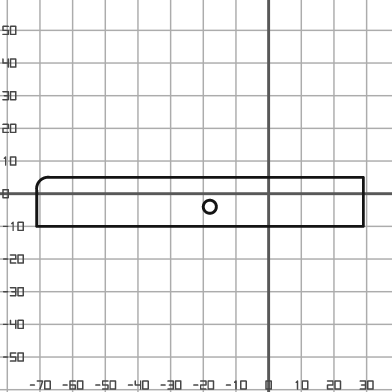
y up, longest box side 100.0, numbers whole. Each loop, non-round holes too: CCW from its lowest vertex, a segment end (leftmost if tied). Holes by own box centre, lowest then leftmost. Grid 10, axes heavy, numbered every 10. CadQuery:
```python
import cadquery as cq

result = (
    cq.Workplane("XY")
    .moveTo(-71.0, -10.0)
    .lineTo(29.0, -10.0)
    .lineTo(29.0, 5.0)
    .lineTo(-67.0, 5.0)
    .threePointArc((-70.0, 4.0), (-71.0, 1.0))
    .close()
    .moveTo(-18.0, -4.0)
    .circle(2.0)
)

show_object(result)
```